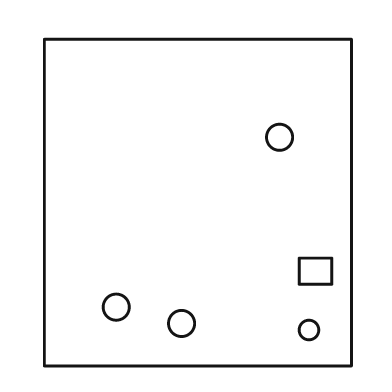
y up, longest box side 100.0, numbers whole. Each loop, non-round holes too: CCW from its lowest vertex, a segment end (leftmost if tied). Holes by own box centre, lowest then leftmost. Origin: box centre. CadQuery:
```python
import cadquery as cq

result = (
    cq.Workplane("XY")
    .moveTo(-47.0, -50.0)
    .lineTo(47.0, -50.0)
    .lineTo(47.0, 50.0)
    .lineTo(-47.0, 50.0)
    .close()
    .moveTo(34.0, -39.0)
    .circle(3.0)
    .moveTo(-5.0, -37.0)
    .circle(4.0)
    .moveTo(-25.0, -32.0)
    .circle(4.0)
    .moveTo(31.0, -25.0)
    .lineTo(41.0, -25.0)
    .lineTo(41.0, -17.0)
    .lineTo(31.0, -17.0)
    .close()
    .moveTo(25.0, 20.0)
    .circle(4.0)
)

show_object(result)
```